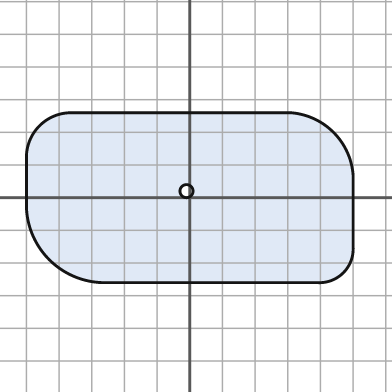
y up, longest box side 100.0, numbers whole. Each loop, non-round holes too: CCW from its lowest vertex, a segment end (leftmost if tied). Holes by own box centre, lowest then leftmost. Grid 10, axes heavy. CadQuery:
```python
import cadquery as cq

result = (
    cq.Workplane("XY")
    .moveTo(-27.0, -26.0)
    .lineTo(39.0, -26.0)
    .threePointArc((47.0, -23.0), (50.0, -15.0))
    .lineTo(50.0, 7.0)
    .threePointArc((44.0, 20.0), (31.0, 26.0))
    .lineTo(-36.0, 26.0)
    .threePointArc((-46.0, 22.0), (-50.0, 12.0))
    .lineTo(-50.0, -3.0)
    .threePointArc((-43.0, -19.0), (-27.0, -26.0))
    .close()
    .moveTo(-1.0, 2.0)
    .circle(2.0)
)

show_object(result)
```